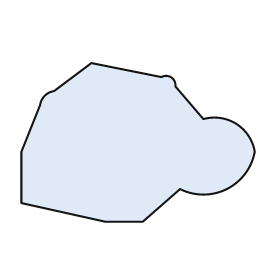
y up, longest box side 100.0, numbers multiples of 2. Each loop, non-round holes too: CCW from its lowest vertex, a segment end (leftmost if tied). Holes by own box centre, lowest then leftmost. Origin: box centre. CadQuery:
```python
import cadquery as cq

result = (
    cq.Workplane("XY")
    .moveTo(-14.0, -34.0)
    .lineTo(2.0, -34.0)
    .lineTo(18.0, -20.0)
    .threePointArc((38.0, -20.0), (50.0, -4.0))
    .threePointArc((42.0, 8.0), (28.0, 10.0))
    .lineTo(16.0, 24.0)
    .threePointArc((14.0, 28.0), (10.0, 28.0))
    .lineTo(-20.0, 34.0)
    .lineTo(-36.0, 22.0)
    .threePointArc((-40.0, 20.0), (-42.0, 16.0))
    .lineTo(-50.0, -4.0)
    .lineTo(-50.0, -26.0)
    .close()
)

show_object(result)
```